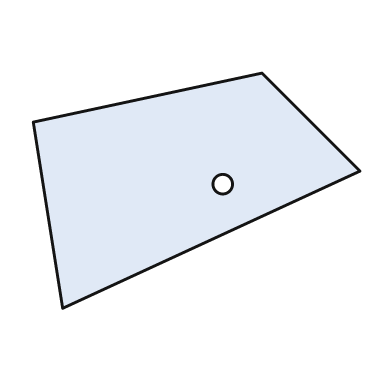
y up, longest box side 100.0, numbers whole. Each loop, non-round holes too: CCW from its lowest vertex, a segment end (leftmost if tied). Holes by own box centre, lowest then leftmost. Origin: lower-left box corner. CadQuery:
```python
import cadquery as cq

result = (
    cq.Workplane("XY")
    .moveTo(9.0, 0.0)
    .lineTo(100.0, 42.0)
    .lineTo(70.0, 72.0)
    .lineTo(0.0, 57.0)
    .close()
    .moveTo(58.0, 38.0)
    .circle(3.0)
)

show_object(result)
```